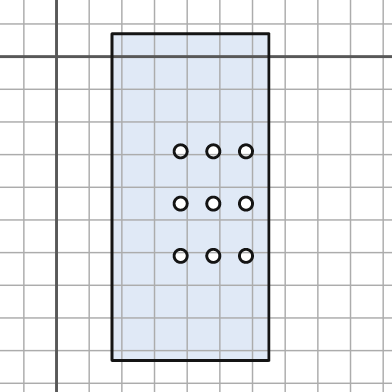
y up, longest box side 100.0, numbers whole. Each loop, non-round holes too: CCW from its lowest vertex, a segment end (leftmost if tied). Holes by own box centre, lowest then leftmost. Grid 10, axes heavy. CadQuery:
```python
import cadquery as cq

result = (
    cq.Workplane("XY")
    .moveTo(17.0, -93.0)
    .lineTo(65.0, -93.0)
    .lineTo(65.0, 7.0)
    .lineTo(17.0, 7.0)
    .close()
    .moveTo(38.0, -61.0)
    .circle(2.0)
    .moveTo(48.0, -61.0)
    .circle(2.0)
    .moveTo(58.0, -61.0)
    .circle(2.0)
    .moveTo(38.0, -45.0)
    .circle(2.0)
    .moveTo(48.0, -45.0)
    .circle(2.0)
    .moveTo(58.0, -45.0)
    .circle(2.0)
    .moveTo(38.0, -29.0)
    .circle(2.0)
    .moveTo(48.0, -29.0)
    .circle(2.0)
    .moveTo(58.0, -29.0)
    .circle(2.0)
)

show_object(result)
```